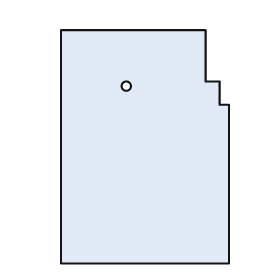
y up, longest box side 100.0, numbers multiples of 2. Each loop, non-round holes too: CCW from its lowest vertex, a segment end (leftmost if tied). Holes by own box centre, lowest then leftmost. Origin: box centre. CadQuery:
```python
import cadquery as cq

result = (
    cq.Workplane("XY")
    .moveTo(-36.0, -50.0)
    .lineTo(36.0, -50.0)
    .lineTo(36.0, 18.0)
    .lineTo(32.0, 18.0)
    .lineTo(32.0, 28.0)
    .lineTo(26.0, 28.0)
    .lineTo(26.0, 50.0)
    .lineTo(-36.0, 50.0)
    .close()
    .moveTo(-8.0, 26.0)
    .circle(2.0)
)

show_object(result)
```